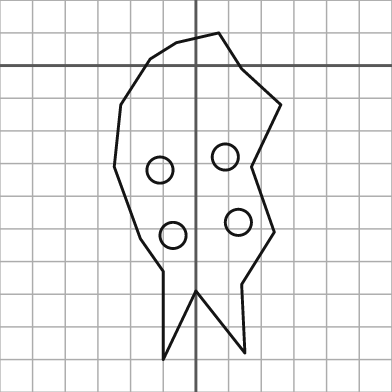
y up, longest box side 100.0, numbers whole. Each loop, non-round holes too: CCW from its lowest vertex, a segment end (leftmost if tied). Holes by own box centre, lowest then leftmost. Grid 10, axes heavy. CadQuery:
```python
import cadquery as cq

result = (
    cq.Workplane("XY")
    .moveTo(-10.0, -90.0)
    .lineTo(0.0, -69.0)
    .lineTo(15.0, -88.0)
    .lineTo(14.0, -67.0)
    .lineTo(24.0, -51.0)
    .lineTo(17.0, -31.0)
    .lineTo(26.0, -12.0)
    .lineTo(14.0, -1.0)
    .lineTo(7.0, 10.0)
    .lineTo(-6.0, 7.0)
    .lineTo(-14.0, 2.0)
    .lineTo(-23.0, -12.0)
    .lineTo(-25.0, -31.0)
    .lineTo(-17.0, -53.0)
    .lineTo(-10.0, -63.0)
    .close()
    .moveTo(-7.0, -52.0)
    .circle(4.0)
    .moveTo(13.0, -48.0)
    .circle(4.0)
    .moveTo(-11.0, -32.0)
    .circle(4.0)
    .moveTo(9.0, -28.0)
    .circle(4.0)
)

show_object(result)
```